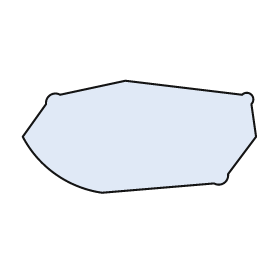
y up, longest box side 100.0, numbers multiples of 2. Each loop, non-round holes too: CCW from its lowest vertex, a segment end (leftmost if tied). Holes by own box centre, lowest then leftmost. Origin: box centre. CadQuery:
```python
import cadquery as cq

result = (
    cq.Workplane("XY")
    .moveTo(-16.0, -24.0)
    .lineTo(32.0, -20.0)
    .threePointArc((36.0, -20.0), (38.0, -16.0))
    .lineTo(50.0, 0.0)
    .lineTo(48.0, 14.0)
    .threePointArc((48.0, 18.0), (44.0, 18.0))
    .lineTo(-6.0, 24.0)
    .lineTo(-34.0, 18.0)
    .threePointArc((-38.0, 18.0), (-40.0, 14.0))
    .lineTo(-50.0, 0.0)
    .threePointArc((-36.0, -16.0), (-16.0, -24.0))
    .close()
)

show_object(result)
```